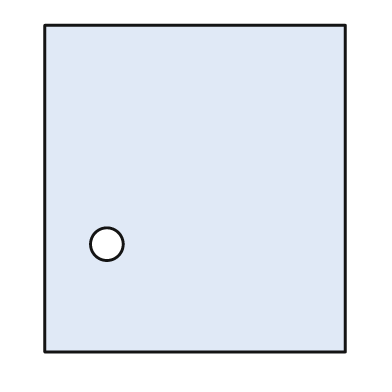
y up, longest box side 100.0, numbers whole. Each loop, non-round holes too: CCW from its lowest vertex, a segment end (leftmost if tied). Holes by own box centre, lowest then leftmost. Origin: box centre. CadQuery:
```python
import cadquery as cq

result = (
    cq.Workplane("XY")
    .moveTo(-46.0, -50.0)
    .lineTo(46.0, -50.0)
    .lineTo(46.0, 50.0)
    .lineTo(-46.0, 50.0)
    .close()
    .moveTo(-27.0, -17.0)
    .circle(5.0)
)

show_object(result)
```